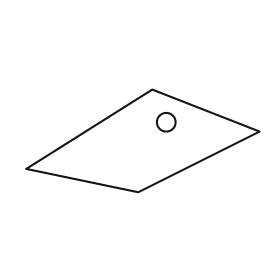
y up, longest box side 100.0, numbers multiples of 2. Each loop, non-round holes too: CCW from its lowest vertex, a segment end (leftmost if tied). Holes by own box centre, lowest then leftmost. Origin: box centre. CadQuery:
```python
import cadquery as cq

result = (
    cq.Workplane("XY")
    .moveTo(-2.0, -22.0)
    .lineTo(50.0, 4.0)
    .lineTo(4.0, 22.0)
    .lineTo(-50.0, -12.0)
    .close()
    .moveTo(10.0, 8.0)
    .circle(4.0)
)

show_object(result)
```